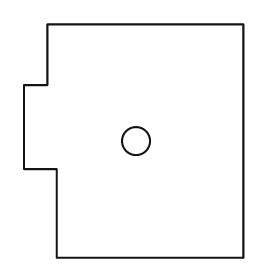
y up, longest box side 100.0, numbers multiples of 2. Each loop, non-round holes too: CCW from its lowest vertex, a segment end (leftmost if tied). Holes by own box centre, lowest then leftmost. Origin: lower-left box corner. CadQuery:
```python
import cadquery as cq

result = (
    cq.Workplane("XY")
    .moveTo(14.0, 0.0)
    .lineTo(94.0, 0.0)
    .lineTo(94.0, 100.0)
    .lineTo(10.0, 100.0)
    .lineTo(10.0, 74.0)
    .lineTo(0.0, 74.0)
    .lineTo(0.0, 38.0)
    .lineTo(14.0, 38.0)
    .close()
    .moveTo(48.0, 50.0)
    .circle(6.0)
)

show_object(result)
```